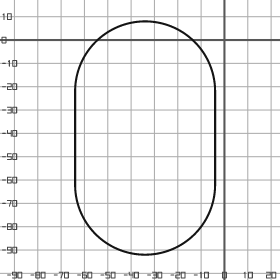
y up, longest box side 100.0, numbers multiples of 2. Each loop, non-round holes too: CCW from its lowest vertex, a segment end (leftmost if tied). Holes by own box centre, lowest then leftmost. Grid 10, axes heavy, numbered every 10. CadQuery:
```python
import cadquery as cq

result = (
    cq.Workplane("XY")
    .moveTo(-64.0, -62.0)
    .threePointArc((-34.0, -92.0), (-4.0, -62.0))
    .lineTo(-4.0, -22.0)
    .threePointArc((-34.0, 8.0), (-64.0, -22.0))
    .close()
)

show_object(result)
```